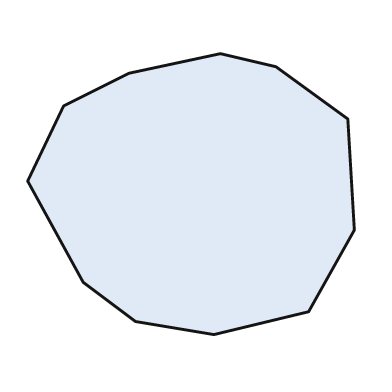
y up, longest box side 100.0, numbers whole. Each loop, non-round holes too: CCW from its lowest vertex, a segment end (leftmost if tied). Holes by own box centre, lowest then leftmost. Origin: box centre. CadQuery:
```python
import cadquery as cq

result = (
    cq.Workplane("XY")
    .moveTo(7.0, -43.0)
    .lineTo(36.0, -36.0)
    .lineTo(50.0, -11.0)
    .lineTo(48.0, 23.0)
    .lineTo(26.0, 39.0)
    .lineTo(9.0, 43.0)
    .lineTo(-19.0, 37.0)
    .lineTo(-39.0, 27.0)
    .lineTo(-50.0, 4.0)
    .lineTo(-33.0, -27.0)
    .lineTo(-17.0, -39.0)
    .close()
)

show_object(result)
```